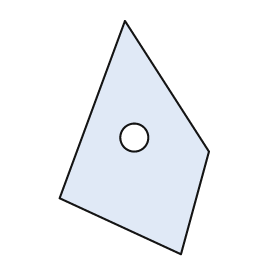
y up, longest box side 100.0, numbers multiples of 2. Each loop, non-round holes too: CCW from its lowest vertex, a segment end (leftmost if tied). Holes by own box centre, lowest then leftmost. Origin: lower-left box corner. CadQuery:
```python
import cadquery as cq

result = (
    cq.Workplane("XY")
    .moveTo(52.0, 0.0)
    .lineTo(64.0, 44.0)
    .lineTo(28.0, 100.0)
    .lineTo(0.0, 24.0)
    .close()
    .moveTo(32.0, 50.0)
    .circle(6.0)
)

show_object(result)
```